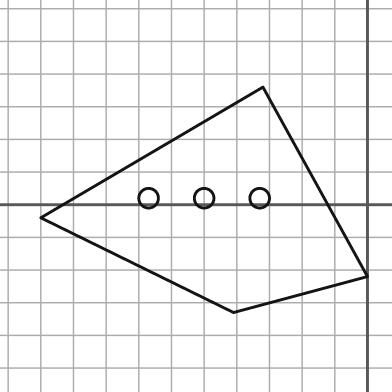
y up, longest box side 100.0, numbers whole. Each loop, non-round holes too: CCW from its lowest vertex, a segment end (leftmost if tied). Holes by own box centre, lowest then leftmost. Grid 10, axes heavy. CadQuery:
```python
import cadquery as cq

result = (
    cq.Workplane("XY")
    .moveTo(-41.0, -33.0)
    .lineTo(0.0, -22.0)
    .lineTo(-32.0, 36.0)
    .lineTo(-100.0, -4.0)
    .close()
    .moveTo(-67.0, 2.0)
    .circle(3.0)
    .moveTo(-50.0, 2.0)
    .circle(3.0)
    .moveTo(-33.0, 2.0)
    .circle(3.0)
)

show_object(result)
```